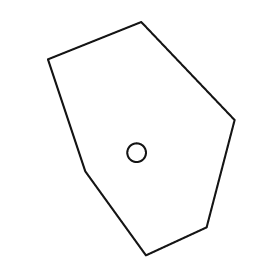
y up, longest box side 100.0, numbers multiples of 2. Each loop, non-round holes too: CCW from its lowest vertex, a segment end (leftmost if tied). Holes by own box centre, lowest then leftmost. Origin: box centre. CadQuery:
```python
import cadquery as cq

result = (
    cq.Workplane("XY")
    .moveTo(2.0, -50.0)
    .lineTo(28.0, -38.0)
    .lineTo(40.0, 8.0)
    .lineTo(0.0, 50.0)
    .lineTo(-40.0, 34.0)
    .lineTo(-24.0, -14.0)
    .close()
    .moveTo(-2.0, -6.0)
    .circle(4.0)
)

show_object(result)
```